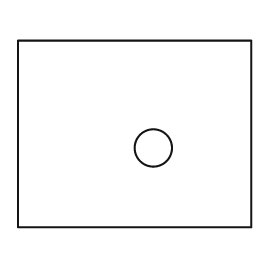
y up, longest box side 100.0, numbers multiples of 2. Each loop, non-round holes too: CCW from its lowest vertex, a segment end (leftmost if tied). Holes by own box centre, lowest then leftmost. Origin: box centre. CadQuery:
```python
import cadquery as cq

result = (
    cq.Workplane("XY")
    .moveTo(-50.0, -40.0)
    .lineTo(50.0, -40.0)
    .lineTo(50.0, 40.0)
    .lineTo(-50.0, 40.0)
    .close()
    .moveTo(8.0, -6.0)
    .circle(8.0)
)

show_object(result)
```